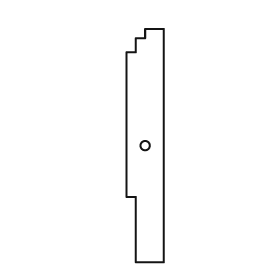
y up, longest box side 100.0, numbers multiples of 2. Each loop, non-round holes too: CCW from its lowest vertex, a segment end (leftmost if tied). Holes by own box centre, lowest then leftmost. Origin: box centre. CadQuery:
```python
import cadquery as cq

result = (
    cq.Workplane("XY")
    .moveTo(-4.0, -50.0)
    .lineTo(8.0, -50.0)
    .lineTo(8.0, 50.0)
    .lineTo(0.0, 50.0)
    .lineTo(0.0, 46.0)
    .lineTo(-4.0, 46.0)
    .lineTo(-4.0, 40.0)
    .lineTo(-8.0, 40.0)
    .lineTo(-8.0, -22.0)
    .lineTo(-4.0, -22.0)
    .close()
    .moveTo(0.0, 0.0)
    .circle(2.0)
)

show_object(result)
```